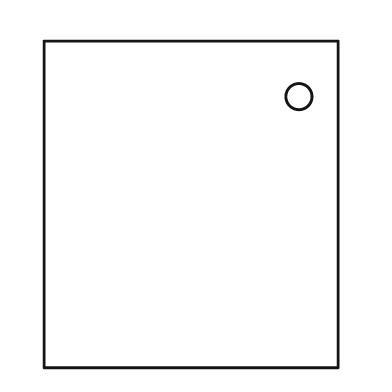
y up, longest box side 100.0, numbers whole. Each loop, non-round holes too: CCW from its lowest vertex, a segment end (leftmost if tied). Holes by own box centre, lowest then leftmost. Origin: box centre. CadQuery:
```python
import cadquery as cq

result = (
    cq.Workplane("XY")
    .moveTo(-45.0, -50.0)
    .lineTo(45.0, -50.0)
    .lineTo(45.0, 50.0)
    .lineTo(-45.0, 50.0)
    .close()
    .moveTo(33.0, 33.0)
    .circle(4.0)
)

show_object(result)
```